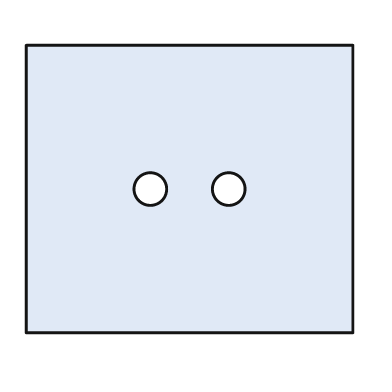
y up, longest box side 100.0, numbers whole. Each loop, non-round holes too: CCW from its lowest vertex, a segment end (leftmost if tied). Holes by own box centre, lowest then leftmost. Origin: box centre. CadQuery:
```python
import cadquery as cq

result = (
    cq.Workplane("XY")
    .moveTo(-50.0, -44.0)
    .lineTo(50.0, -44.0)
    .lineTo(50.0, 44.0)
    .lineTo(-50.0, 44.0)
    .close()
    .moveTo(-12.0, 0.0)
    .circle(5.0)
    .moveTo(12.0, 0.0)
    .circle(5.0)
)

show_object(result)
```